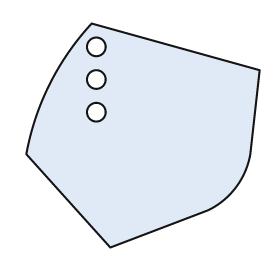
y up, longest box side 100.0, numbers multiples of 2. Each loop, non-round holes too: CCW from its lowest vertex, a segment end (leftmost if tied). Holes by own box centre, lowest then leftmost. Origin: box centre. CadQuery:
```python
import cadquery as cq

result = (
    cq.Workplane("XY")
    .moveTo(-14.0, -48.0)
    .lineTo(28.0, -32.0)
    .threePointArc((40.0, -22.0), (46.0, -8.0))
    .lineTo(50.0, 28.0)
    .lineTo(-22.0, 48.0)
    .threePointArc((-40.0, 22.0), (-50.0, -8.0))
    .close()
    .moveTo(-20.0, 10.0)
    .circle(4.0)
    .moveTo(-20.0, 24.0)
    .circle(4.0)
    .moveTo(-20.0, 38.0)
    .circle(4.0)
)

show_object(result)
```